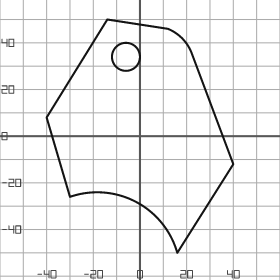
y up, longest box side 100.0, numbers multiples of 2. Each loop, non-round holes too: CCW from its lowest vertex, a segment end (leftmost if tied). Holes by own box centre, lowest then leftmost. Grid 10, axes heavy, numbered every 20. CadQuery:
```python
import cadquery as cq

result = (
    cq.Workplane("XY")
    .moveTo(16.0, -50.0)
    .lineTo(40.0, -12.0)
    .lineTo(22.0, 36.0)
    .threePointArc((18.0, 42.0), (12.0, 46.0))
    .lineTo(-14.0, 50.0)
    .lineTo(-40.0, 8.0)
    .lineTo(-30.0, -26.0)
    .threePointArc((-2.0, -28.0), (16.0, -50.0))
    .close()
    .moveTo(-6.0, 34.0)
    .circle(6.0)
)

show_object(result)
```